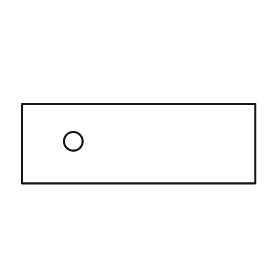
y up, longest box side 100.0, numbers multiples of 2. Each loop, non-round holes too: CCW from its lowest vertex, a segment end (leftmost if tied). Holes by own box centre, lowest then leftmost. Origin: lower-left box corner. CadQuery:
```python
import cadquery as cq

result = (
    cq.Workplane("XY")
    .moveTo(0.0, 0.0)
    .lineTo(100.0, 0.0)
    .lineTo(100.0, 34.0)
    .lineTo(0.0, 34.0)
    .close()
    .moveTo(22.0, 18.0)
    .circle(4.0)
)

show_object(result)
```